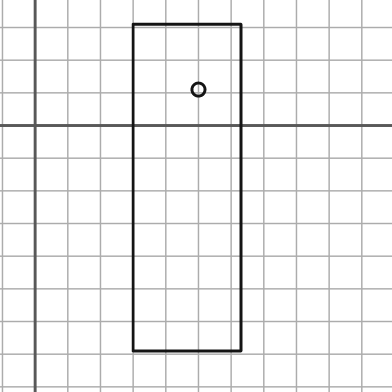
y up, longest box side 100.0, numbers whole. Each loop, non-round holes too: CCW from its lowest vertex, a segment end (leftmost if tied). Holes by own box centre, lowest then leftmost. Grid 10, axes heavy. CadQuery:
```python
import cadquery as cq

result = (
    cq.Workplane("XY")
    .moveTo(30.0, -69.0)
    .lineTo(63.0, -69.0)
    .lineTo(63.0, 31.0)
    .lineTo(30.0, 31.0)
    .close()
    .moveTo(50.0, 11.0)
    .circle(2.0)
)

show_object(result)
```